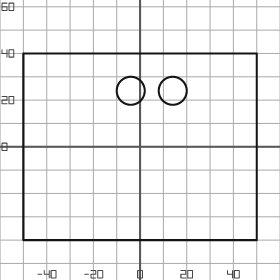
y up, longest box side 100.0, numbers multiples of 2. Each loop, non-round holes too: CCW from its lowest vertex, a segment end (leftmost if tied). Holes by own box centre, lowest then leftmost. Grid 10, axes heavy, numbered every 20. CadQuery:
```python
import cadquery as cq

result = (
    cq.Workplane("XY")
    .moveTo(-50.0, -40.0)
    .lineTo(50.0, -40.0)
    .lineTo(50.0, 40.0)
    .lineTo(-50.0, 40.0)
    .close()
    .moveTo(-4.0, 24.0)
    .circle(6.0)
    .moveTo(14.0, 24.0)
    .circle(6.0)
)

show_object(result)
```